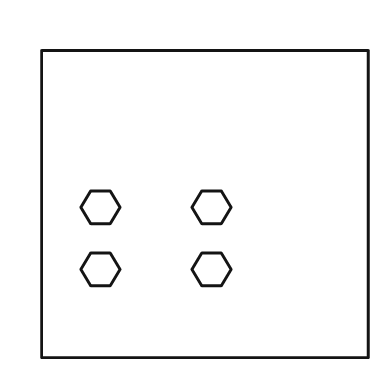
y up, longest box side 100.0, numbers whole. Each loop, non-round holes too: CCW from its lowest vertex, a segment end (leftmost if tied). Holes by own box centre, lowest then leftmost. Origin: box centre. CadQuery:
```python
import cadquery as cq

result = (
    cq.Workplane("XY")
    .moveTo(-50.0, -47.0)
    .lineTo(50.0, -47.0)
    .lineTo(50.0, 47.0)
    .lineTo(-50.0, 47.0)
    .close()
    .moveTo(-35.0, -25.0)
    .lineTo(-29.0, -25.0)
    .lineTo(-26.0, -20.0)
    .lineTo(-29.0, -15.0)
    .lineTo(-35.0, -15.0)
    .lineTo(-38.0, -20.0)
    .close()
    .moveTo(-1.0, -25.0)
    .lineTo(5.0, -25.0)
    .lineTo(8.0, -20.0)
    .lineTo(5.0, -15.0)
    .lineTo(-1.0, -15.0)
    .lineTo(-4.0, -20.0)
    .close()
    .moveTo(-35.0, -6.0)
    .lineTo(-29.0, -6.0)
    .lineTo(-26.0, -1.0)
    .lineTo(-29.0, 4.0)
    .lineTo(-35.0, 4.0)
    .lineTo(-38.0, -1.0)
    .close()
    .moveTo(-1.0, -6.0)
    .lineTo(5.0, -6.0)
    .lineTo(8.0, -1.0)
    .lineTo(5.0, 4.0)
    .lineTo(-1.0, 4.0)
    .lineTo(-4.0, -1.0)
    .close()
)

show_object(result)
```